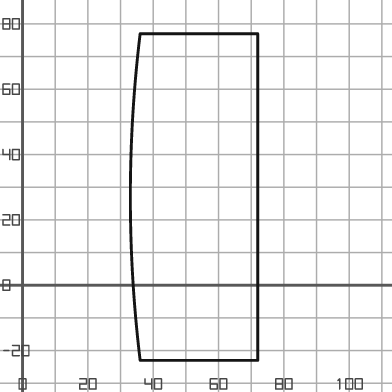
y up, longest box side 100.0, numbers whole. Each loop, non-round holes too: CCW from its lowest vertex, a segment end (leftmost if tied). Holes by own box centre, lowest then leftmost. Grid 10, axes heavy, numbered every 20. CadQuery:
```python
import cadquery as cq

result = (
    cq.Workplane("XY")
    .moveTo(36.0, -23.0)
    .lineTo(72.0, -23.0)
    .lineTo(72.0, 77.0)
    .lineTo(36.0, 77.0)
    .threePointArc((33.0, 27.0), (36.0, -23.0))
    .close()
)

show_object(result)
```